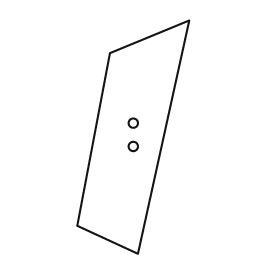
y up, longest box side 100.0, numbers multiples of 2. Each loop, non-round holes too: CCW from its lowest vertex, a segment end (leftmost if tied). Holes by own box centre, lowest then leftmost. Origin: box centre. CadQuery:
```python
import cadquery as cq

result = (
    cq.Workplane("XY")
    .moveTo(2.0, -50.0)
    .lineTo(24.0, 50.0)
    .lineTo(-10.0, 36.0)
    .lineTo(-24.0, -38.0)
    .close()
    .moveTo(0.0, -4.0)
    .circle(2.0)
    .moveTo(0.0, 6.0)
    .circle(2.0)
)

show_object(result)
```